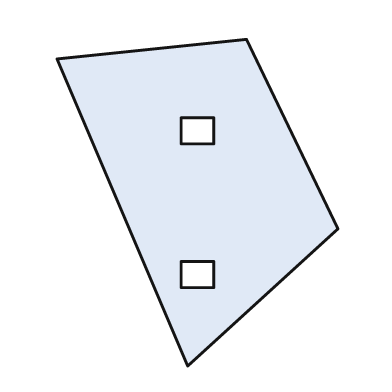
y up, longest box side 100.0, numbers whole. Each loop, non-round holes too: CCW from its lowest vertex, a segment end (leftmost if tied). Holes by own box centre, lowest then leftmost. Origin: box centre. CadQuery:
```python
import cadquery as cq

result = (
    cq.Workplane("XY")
    .moveTo(-3.0, -50.0)
    .lineTo(43.0, -8.0)
    .lineTo(15.0, 50.0)
    .lineTo(-43.0, 44.0)
    .close()
    .moveTo(-5.0, -26.0)
    .lineTo(5.0, -26.0)
    .lineTo(5.0, -18.0)
    .lineTo(-5.0, -18.0)
    .close()
    .moveTo(-5.0, 18.0)
    .lineTo(5.0, 18.0)
    .lineTo(5.0, 26.0)
    .lineTo(-5.0, 26.0)
    .close()
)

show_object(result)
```